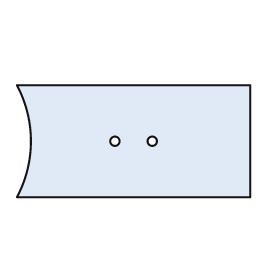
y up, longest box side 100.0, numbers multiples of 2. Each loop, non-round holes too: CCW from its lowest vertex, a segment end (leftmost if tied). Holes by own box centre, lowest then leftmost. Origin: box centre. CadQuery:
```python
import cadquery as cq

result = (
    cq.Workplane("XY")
    .moveTo(-50.0, -24.0)
    .lineTo(50.0, -24.0)
    .lineTo(50.0, 24.0)
    .lineTo(-50.0, 24.0)
    .threePointArc((-44.0, 0.0), (-50.0, -24.0))
    .close()
    .moveTo(-8.0, 0.0)
    .circle(2.0)
    .moveTo(8.0, 0.0)
    .circle(2.0)
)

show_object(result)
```